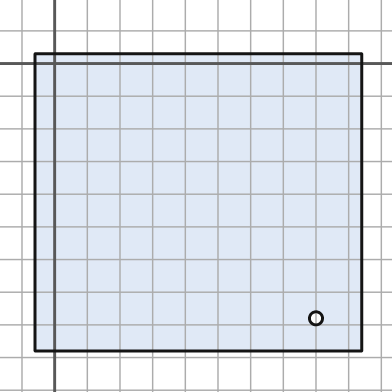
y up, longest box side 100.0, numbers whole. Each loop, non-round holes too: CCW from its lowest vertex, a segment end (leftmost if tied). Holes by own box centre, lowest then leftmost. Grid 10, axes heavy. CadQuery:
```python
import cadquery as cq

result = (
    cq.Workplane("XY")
    .moveTo(-6.0, -88.0)
    .lineTo(94.0, -88.0)
    .lineTo(94.0, 3.0)
    .lineTo(-6.0, 3.0)
    .close()
    .moveTo(80.0, -78.0)
    .circle(2.0)
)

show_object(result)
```